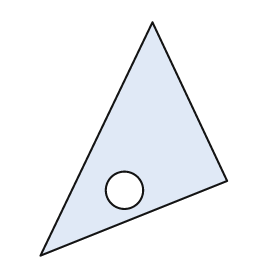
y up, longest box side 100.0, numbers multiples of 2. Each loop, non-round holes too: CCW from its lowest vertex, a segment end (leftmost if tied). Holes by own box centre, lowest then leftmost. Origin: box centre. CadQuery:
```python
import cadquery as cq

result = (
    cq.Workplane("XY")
    .moveTo(-40.0, -50.0)
    .lineTo(40.0, -18.0)
    .lineTo(8.0, 50.0)
    .close()
    .moveTo(-4.0, -22.0)
    .circle(8.0)
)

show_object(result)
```